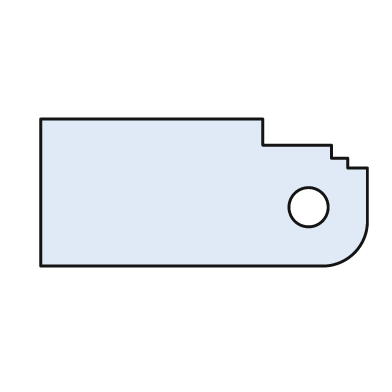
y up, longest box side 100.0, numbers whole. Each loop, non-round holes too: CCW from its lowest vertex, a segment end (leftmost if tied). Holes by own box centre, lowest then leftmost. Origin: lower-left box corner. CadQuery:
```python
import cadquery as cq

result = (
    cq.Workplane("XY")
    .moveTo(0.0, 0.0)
    .lineTo(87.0, 0.0)
    .threePointArc((96.0, 4.0), (100.0, 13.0))
    .lineTo(100.0, 30.0)
    .lineTo(94.0, 30.0)
    .lineTo(94.0, 33.0)
    .lineTo(89.0, 33.0)
    .lineTo(89.0, 37.0)
    .lineTo(68.0, 37.0)
    .lineTo(68.0, 45.0)
    .lineTo(0.0, 45.0)
    .close()
    .moveTo(82.0, 18.0)
    .circle(6.0)
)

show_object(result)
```